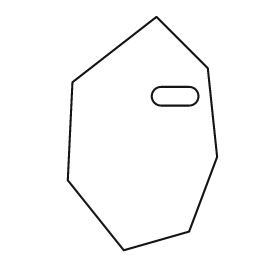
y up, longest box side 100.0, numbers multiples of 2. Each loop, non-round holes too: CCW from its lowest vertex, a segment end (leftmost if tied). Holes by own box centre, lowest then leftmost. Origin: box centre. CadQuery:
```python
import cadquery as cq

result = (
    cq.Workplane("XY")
    .moveTo(-8.0, -50.0)
    .lineTo(20.0, -42.0)
    .lineTo(32.0, -10.0)
    .lineTo(28.0, 28.0)
    .lineTo(6.0, 50.0)
    .lineTo(-30.0, 22.0)
    .lineTo(-32.0, -20.0)
    .close()
    .moveTo(8.0, 12.0)
    .lineTo(20.0, 12.0)
    .threePointArc((24.0, 16.0), (20.0, 20.0))
    .lineTo(8.0, 20.0)
    .threePointArc((4.0, 16.0), (8.0, 12.0))
    .close()
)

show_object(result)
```